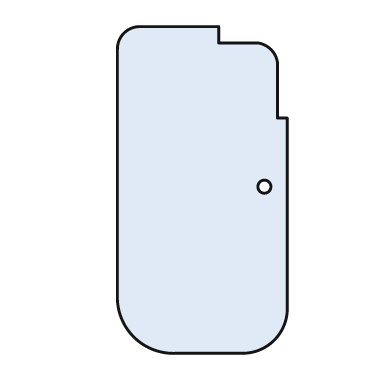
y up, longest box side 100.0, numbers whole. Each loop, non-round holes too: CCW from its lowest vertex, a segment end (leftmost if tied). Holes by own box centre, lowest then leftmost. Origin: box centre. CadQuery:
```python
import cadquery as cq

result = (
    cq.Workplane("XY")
    .moveTo(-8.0, -50.0)
    .lineTo(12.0, -50.0)
    .threePointArc((22.0, -46.0), (26.0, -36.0))
    .lineTo(26.0, 22.0)
    .lineTo(23.0, 22.0)
    .lineTo(23.0, 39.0)
    .threePointArc((21.0, 43.0), (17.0, 45.0))
    .lineTo(5.0, 45.0)
    .lineTo(5.0, 50.0)
    .lineTo(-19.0, 50.0)
    .threePointArc((-24.0, 48.0), (-26.0, 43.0))
    .lineTo(-26.0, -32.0)
    .threePointArc((-21.0, -45.0), (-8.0, -50.0))
    .close()
    .moveTo(19.0, 1.0)
    .circle(2.0)
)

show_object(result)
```